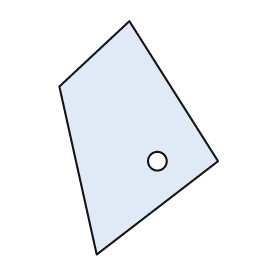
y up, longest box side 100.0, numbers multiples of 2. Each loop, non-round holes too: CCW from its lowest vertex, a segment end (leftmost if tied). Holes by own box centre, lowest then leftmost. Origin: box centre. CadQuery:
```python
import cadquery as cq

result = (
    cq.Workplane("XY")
    .moveTo(-18.0, -50.0)
    .lineTo(34.0, -10.0)
    .lineTo(-4.0, 50.0)
    .lineTo(-34.0, 22.0)
    .close()
    .moveTo(8.0, -10.0)
    .circle(4.0)
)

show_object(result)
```